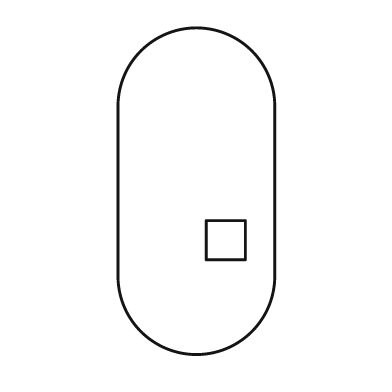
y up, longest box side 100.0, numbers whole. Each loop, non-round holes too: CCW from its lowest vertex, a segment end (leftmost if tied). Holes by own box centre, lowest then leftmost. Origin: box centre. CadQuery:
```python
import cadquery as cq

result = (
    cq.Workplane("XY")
    .moveTo(-24.0, -26.0)
    .threePointArc((0.0, -50.0), (24.0, -26.0))
    .lineTo(24.0, 26.0)
    .threePointArc((0.0, 50.0), (-24.0, 26.0))
    .close()
    .moveTo(3.0, -21.0)
    .lineTo(15.0, -21.0)
    .lineTo(15.0, -9.0)
    .lineTo(3.0, -9.0)
    .close()
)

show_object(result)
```